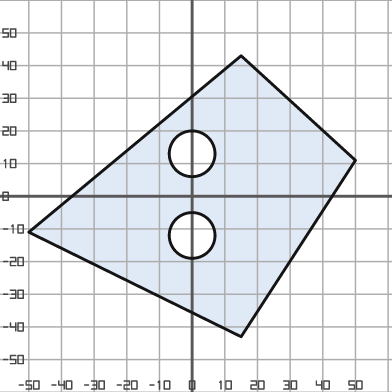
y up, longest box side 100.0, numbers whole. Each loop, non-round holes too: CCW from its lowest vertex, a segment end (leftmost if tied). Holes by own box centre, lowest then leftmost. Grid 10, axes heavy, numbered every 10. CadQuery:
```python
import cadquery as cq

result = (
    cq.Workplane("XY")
    .moveTo(15.0, -43.0)
    .lineTo(50.0, 11.0)
    .lineTo(15.0, 43.0)
    .lineTo(-50.0, -11.0)
    .close()
    .moveTo(0.0, -12.0)
    .circle(7.0)
    .moveTo(0.0, 13.0)
    .circle(7.0)
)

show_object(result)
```